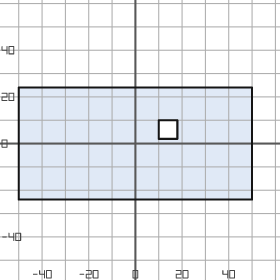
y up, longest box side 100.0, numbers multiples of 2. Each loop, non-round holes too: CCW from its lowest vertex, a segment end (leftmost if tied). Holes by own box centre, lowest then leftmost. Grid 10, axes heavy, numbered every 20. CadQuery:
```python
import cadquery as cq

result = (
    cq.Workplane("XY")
    .moveTo(-50.0, -24.0)
    .lineTo(50.0, -24.0)
    .lineTo(50.0, 24.0)
    .lineTo(-50.0, 24.0)
    .close()
    .moveTo(10.0, 2.0)
    .lineTo(18.0, 2.0)
    .lineTo(18.0, 10.0)
    .lineTo(10.0, 10.0)
    .close()
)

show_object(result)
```